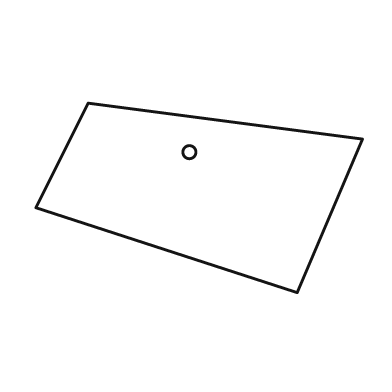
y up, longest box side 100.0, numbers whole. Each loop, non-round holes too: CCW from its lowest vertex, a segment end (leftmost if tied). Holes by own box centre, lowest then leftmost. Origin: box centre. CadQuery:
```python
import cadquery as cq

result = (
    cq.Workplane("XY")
    .moveTo(30.0, -29.0)
    .lineTo(50.0, 18.0)
    .lineTo(-34.0, 29.0)
    .lineTo(-50.0, -3.0)
    .close()
    .moveTo(-3.0, 14.0)
    .circle(2.0)
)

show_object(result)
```